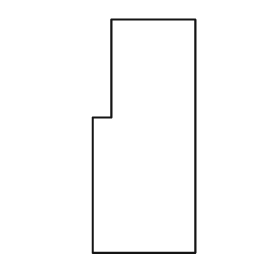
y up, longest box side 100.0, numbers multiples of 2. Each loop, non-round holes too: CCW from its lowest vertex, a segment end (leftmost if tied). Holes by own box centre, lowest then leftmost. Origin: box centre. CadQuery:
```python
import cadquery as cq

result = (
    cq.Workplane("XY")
    .moveTo(-22.0, -50.0)
    .lineTo(22.0, -50.0)
    .lineTo(22.0, 50.0)
    .lineTo(-14.0, 50.0)
    .lineTo(-14.0, 8.0)
    .lineTo(-22.0, 8.0)
    .close()
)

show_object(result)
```